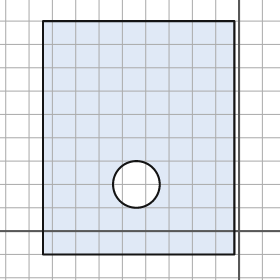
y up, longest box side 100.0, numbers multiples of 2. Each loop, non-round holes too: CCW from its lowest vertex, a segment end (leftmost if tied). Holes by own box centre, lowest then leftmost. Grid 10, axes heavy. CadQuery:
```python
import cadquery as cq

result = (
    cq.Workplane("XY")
    .moveTo(-84.0, -10.0)
    .lineTo(-2.0, -10.0)
    .lineTo(-2.0, 90.0)
    .lineTo(-84.0, 90.0)
    .close()
    .moveTo(-44.0, 20.0)
    .circle(10.0)
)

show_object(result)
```